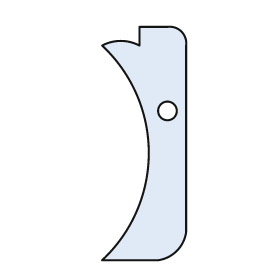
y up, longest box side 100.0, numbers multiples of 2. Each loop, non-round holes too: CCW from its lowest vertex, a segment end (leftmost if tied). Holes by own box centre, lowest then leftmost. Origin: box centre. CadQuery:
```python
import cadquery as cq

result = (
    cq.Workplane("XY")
    .moveTo(-18.0, -50.0)
    .lineTo(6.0, -50.0)
    .threePointArc((14.0, -46.0), (18.0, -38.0))
    .lineTo(18.0, 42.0)
    .threePointArc((16.0, 48.0), (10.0, 50.0))
    .lineTo(-2.0, 50.0)
    .lineTo(-2.0, 42.0)
    .threePointArc((-10.0, 44.0), (-18.0, 42.0))
    .threePointArc((2.0, -4.0), (-18.0, -50.0))
    .close()
    .moveTo(10.0, 14.0)
    .circle(4.0)
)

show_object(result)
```